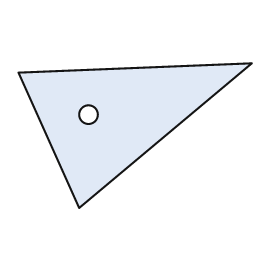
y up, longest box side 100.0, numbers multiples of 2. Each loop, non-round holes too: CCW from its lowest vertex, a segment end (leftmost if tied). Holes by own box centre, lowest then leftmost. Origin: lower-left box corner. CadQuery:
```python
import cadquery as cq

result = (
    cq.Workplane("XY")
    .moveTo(26.0, 0.0)
    .lineTo(100.0, 62.0)
    .lineTo(0.0, 58.0)
    .close()
    .moveTo(30.0, 40.0)
    .circle(4.0)
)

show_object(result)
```